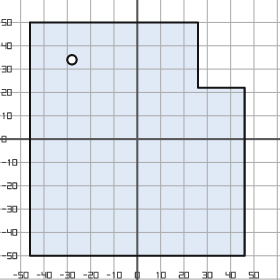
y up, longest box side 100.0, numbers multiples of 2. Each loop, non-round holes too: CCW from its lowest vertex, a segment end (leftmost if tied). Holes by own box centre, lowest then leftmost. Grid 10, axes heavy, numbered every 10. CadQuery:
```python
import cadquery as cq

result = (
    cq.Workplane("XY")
    .moveTo(-46.0, -50.0)
    .lineTo(46.0, -50.0)
    .lineTo(46.0, 22.0)
    .lineTo(26.0, 22.0)
    .lineTo(26.0, 50.0)
    .lineTo(-46.0, 50.0)
    .close()
    .moveTo(-28.0, 34.0)
    .circle(2.0)
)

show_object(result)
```